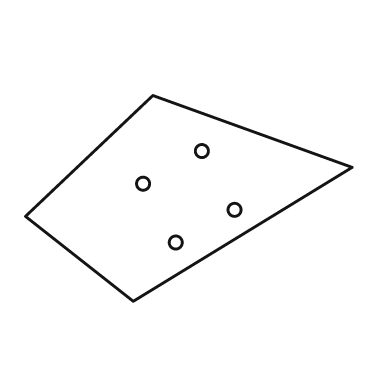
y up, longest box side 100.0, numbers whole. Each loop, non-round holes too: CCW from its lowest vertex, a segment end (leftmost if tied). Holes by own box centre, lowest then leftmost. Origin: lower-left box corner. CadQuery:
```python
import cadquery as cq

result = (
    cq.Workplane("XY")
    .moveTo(33.0, 0.0)
    .lineTo(100.0, 41.0)
    .lineTo(39.0, 63.0)
    .lineTo(0.0, 26.0)
    .close()
    .moveTo(46.0, 18.0)
    .circle(2.0)
    .moveTo(64.0, 28.0)
    .circle(2.0)
    .moveTo(36.0, 36.0)
    .circle(2.0)
    .moveTo(54.0, 46.0)
    .circle(2.0)
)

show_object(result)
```